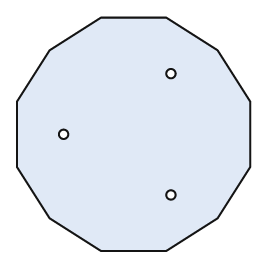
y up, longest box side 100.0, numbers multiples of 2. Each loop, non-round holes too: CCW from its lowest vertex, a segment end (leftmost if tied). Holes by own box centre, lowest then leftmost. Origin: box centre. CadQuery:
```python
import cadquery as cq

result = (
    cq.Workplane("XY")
    .moveTo(-14.0, -50.0)
    .lineTo(14.0, -50.0)
    .lineTo(36.0, -36.0)
    .lineTo(50.0, -14.0)
    .lineTo(50.0, 14.0)
    .lineTo(36.0, 36.0)
    .lineTo(14.0, 50.0)
    .lineTo(-14.0, 50.0)
    .lineTo(-36.0, 36.0)
    .lineTo(-50.0, 14.0)
    .lineTo(-50.0, -14.0)
    .lineTo(-36.0, -36.0)
    .close()
    .moveTo(16.0, -26.0)
    .circle(2.0)
    .moveTo(-30.0, 0.0)
    .circle(2.0)
    .moveTo(16.0, 26.0)
    .circle(2.0)
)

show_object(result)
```